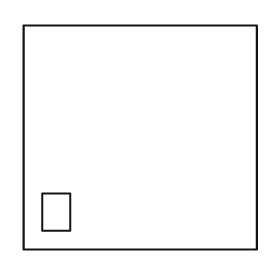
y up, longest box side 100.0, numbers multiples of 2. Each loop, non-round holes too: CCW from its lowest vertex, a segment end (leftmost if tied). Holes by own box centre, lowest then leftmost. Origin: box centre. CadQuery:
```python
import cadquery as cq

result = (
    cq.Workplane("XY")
    .moveTo(-50.0, -48.0)
    .lineTo(50.0, -48.0)
    .lineTo(50.0, 48.0)
    .lineTo(-50.0, 48.0)
    .close()
    .moveTo(-42.0, -40.0)
    .lineTo(-30.0, -40.0)
    .lineTo(-30.0, -24.0)
    .lineTo(-42.0, -24.0)
    .close()
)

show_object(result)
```